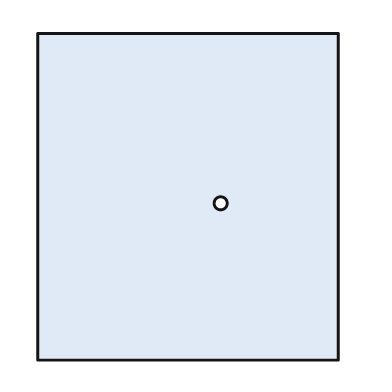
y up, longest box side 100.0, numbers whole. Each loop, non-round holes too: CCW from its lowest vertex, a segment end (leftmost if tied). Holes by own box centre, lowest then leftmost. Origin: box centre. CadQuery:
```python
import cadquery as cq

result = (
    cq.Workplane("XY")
    .moveTo(-46.0, -50.0)
    .lineTo(46.0, -50.0)
    .lineTo(46.0, 50.0)
    .lineTo(-46.0, 50.0)
    .close()
    .moveTo(10.0, -2.0)
    .circle(2.0)
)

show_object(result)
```